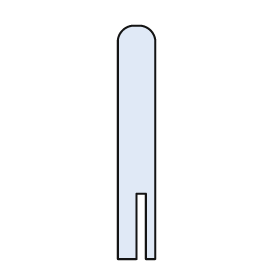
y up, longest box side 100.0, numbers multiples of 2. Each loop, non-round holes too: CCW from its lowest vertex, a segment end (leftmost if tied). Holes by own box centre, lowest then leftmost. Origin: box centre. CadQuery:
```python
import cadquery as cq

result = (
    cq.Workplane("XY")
    .moveTo(-8.0, -50.0)
    .lineTo(0.0, -50.0)
    .lineTo(0.0, -22.0)
    .lineTo(4.0, -22.0)
    .lineTo(4.0, -50.0)
    .lineTo(8.0, -50.0)
    .lineTo(8.0, 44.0)
    .threePointArc((6.0, 48.0), (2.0, 50.0))
    .lineTo(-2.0, 50.0)
    .threePointArc((-6.0, 48.0), (-8.0, 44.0))
    .close()
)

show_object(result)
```